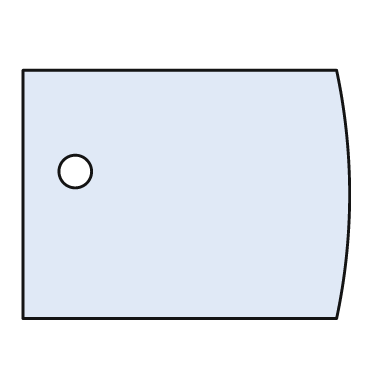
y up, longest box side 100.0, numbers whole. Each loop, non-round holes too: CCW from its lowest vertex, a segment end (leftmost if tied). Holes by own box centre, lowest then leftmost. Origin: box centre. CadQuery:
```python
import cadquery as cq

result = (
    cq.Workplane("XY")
    .moveTo(-50.0, -38.0)
    .lineTo(46.0, -38.0)
    .threePointArc((50.0, 0.0), (46.0, 38.0))
    .lineTo(-50.0, 38.0)
    .close()
    .moveTo(-34.0, 7.0)
    .circle(5.0)
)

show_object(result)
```